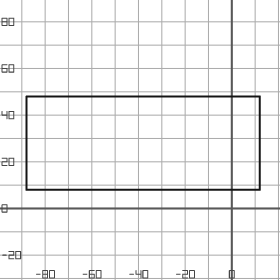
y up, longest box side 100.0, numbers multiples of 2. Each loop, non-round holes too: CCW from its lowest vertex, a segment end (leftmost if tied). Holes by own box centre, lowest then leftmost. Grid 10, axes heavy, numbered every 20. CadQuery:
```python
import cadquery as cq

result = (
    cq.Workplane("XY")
    .moveTo(-88.0, 8.0)
    .lineTo(12.0, 8.0)
    .lineTo(12.0, 48.0)
    .lineTo(-88.0, 48.0)
    .close()
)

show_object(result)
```